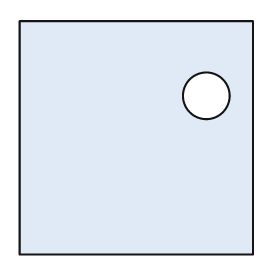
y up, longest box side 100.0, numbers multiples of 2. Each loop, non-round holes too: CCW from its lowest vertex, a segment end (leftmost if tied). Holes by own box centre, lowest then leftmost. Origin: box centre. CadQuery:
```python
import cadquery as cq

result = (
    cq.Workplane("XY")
    .moveTo(-50.0, -50.0)
    .lineTo(50.0, -50.0)
    .lineTo(50.0, 50.0)
    .lineTo(-50.0, 50.0)
    .close()
    .moveTo(30.0, 18.0)
    .circle(10.0)
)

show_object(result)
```